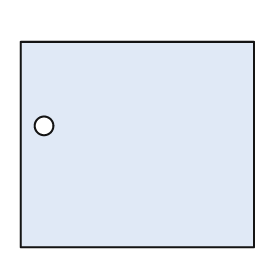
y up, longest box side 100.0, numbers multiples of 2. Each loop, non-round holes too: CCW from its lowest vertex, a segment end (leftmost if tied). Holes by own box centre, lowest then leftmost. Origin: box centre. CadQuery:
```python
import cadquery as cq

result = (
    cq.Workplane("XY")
    .moveTo(-50.0, -44.0)
    .lineTo(50.0, -44.0)
    .lineTo(50.0, 44.0)
    .lineTo(-50.0, 44.0)
    .close()
    .moveTo(-40.0, 8.0)
    .circle(4.0)
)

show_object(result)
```